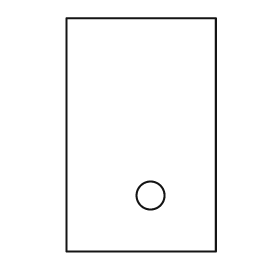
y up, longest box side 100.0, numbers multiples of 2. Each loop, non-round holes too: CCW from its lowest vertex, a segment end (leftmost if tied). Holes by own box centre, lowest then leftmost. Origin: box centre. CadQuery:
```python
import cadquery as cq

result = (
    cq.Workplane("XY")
    .moveTo(-32.0, -50.0)
    .lineTo(32.0, -50.0)
    .lineTo(32.0, 50.0)
    .lineTo(-32.0, 50.0)
    .close()
    .moveTo(4.0, -26.0)
    .circle(6.0)
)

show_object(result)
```